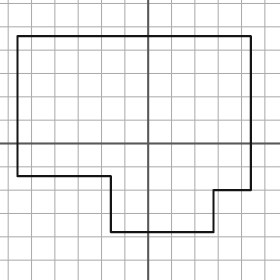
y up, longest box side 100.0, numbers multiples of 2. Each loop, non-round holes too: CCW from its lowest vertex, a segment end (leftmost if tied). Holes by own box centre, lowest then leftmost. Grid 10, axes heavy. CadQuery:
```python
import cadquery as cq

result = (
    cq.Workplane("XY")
    .moveTo(-16.0, -38.0)
    .lineTo(28.0, -38.0)
    .lineTo(28.0, -20.0)
    .lineTo(44.0, -20.0)
    .lineTo(44.0, 46.0)
    .lineTo(-56.0, 46.0)
    .lineTo(-56.0, -14.0)
    .lineTo(-16.0, -14.0)
    .close()
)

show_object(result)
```